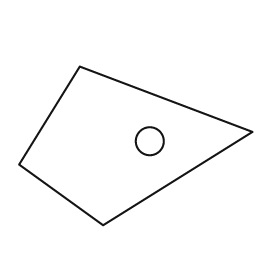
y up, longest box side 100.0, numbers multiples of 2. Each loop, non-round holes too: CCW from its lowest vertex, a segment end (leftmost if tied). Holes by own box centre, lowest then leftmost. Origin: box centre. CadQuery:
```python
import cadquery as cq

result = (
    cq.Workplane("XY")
    .moveTo(-14.0, -34.0)
    .lineTo(50.0, 6.0)
    .lineTo(-24.0, 34.0)
    .lineTo(-50.0, -8.0)
    .close()
    .moveTo(6.0, 2.0)
    .circle(6.0)
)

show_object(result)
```